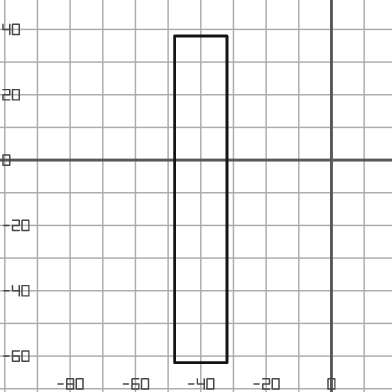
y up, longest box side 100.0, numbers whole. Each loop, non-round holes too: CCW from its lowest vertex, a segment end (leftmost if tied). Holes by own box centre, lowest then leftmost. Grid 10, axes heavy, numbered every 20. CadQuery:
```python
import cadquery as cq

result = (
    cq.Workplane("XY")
    .moveTo(-48.0, -62.0)
    .lineTo(-32.0, -62.0)
    .lineTo(-32.0, 38.0)
    .lineTo(-48.0, 38.0)
    .close()
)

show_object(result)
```